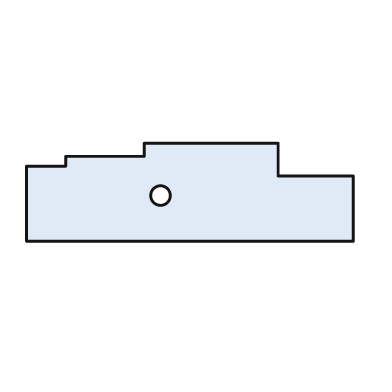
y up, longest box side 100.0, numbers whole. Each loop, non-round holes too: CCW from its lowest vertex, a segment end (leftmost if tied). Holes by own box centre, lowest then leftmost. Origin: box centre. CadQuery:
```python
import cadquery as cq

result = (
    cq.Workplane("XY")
    .moveTo(-50.0, -15.0)
    .lineTo(50.0, -15.0)
    .lineTo(50.0, 5.0)
    .lineTo(27.0, 5.0)
    .lineTo(27.0, 15.0)
    .lineTo(-14.0, 15.0)
    .lineTo(-14.0, 11.0)
    .lineTo(-38.0, 11.0)
    .lineTo(-38.0, 8.0)
    .lineTo(-50.0, 8.0)
    .close()
    .moveTo(-9.0, -1.0)
    .circle(3.0)
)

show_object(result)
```